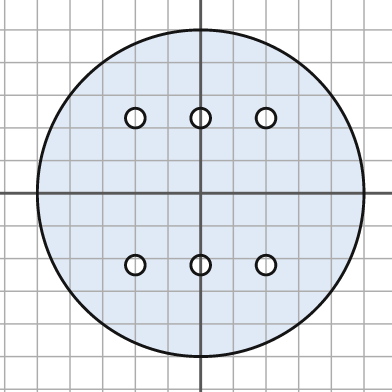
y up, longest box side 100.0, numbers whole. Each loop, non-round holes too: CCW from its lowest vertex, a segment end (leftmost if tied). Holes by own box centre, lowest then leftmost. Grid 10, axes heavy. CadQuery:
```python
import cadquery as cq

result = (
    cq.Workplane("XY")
    .moveTo(0.0, 0.0)
    .circle(50.0)
    .moveTo(-20.0, -22.0)
    .circle(3.0)
    .moveTo(0.0, -22.0)
    .circle(3.0)
    .moveTo(20.0, -22.0)
    .circle(3.0)
    .moveTo(-20.0, 23.0)
    .circle(3.0)
    .moveTo(0.0, 23.0)
    .circle(3.0)
    .moveTo(20.0, 23.0)
    .circle(3.0)
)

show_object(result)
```